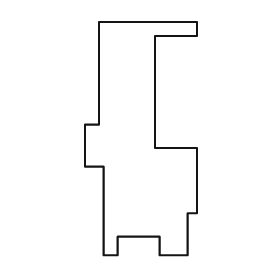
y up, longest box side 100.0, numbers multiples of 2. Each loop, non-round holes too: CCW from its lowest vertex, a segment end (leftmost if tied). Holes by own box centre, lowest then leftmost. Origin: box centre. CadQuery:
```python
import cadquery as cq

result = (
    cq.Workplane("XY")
    .moveTo(-16.0, -50.0)
    .lineTo(-10.0, -50.0)
    .lineTo(-10.0, -42.0)
    .lineTo(8.0, -42.0)
    .lineTo(8.0, -50.0)
    .lineTo(20.0, -50.0)
    .lineTo(20.0, -32.0)
    .lineTo(24.0, -32.0)
    .lineTo(24.0, -4.0)
    .lineTo(6.0, -4.0)
    .lineTo(6.0, 44.0)
    .lineTo(24.0, 44.0)
    .lineTo(24.0, 50.0)
    .lineTo(-18.0, 50.0)
    .lineTo(-18.0, 6.0)
    .lineTo(-24.0, 6.0)
    .lineTo(-24.0, -12.0)
    .lineTo(-16.0, -12.0)
    .close()
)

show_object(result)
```